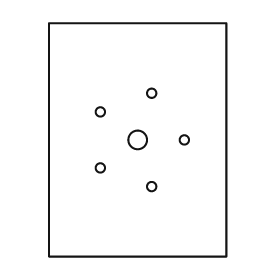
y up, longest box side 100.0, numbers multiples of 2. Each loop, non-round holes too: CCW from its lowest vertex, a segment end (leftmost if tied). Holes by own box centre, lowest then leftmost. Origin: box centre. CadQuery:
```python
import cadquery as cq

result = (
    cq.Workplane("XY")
    .moveTo(-38.0, -50.0)
    .lineTo(38.0, -50.0)
    .lineTo(38.0, 50.0)
    .lineTo(-38.0, 50.0)
    .close()
    .moveTo(6.0, -20.0)
    .circle(2.0)
    .moveTo(-16.0, -12.0)
    .circle(2.0)
    .moveTo(0.0, 0.0)
    .circle(4.0)
    .moveTo(20.0, 0.0)
    .circle(2.0)
    .moveTo(-16.0, 12.0)
    .circle(2.0)
    .moveTo(6.0, 20.0)
    .circle(2.0)
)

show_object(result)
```